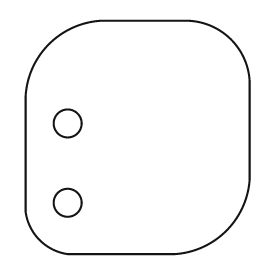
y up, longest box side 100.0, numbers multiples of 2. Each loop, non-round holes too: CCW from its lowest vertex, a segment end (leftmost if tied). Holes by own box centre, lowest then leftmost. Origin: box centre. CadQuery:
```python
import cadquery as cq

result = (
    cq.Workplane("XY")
    .moveTo(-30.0, -50.0)
    .lineTo(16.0, -50.0)
    .threePointArc((38.0, -40.0), (48.0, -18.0))
    .lineTo(48.0, 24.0)
    .threePointArc((40.0, 42.0), (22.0, 50.0))
    .lineTo(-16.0, 50.0)
    .threePointArc((-38.0, 40.0), (-48.0, 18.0))
    .lineTo(-48.0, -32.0)
    .threePointArc((-42.0, -44.0), (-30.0, -50.0))
    .close()
    .moveTo(-30.0, -28.0)
    .circle(6.0)
    .moveTo(-30.0, 6.0)
    .circle(6.0)
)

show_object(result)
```